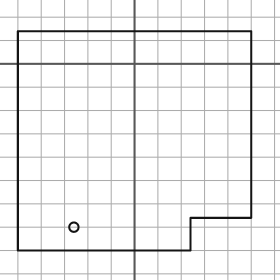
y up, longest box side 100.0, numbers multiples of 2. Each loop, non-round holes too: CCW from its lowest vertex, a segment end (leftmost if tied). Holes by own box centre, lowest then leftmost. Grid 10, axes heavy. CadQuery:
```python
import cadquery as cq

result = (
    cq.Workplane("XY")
    .moveTo(-50.0, -80.0)
    .lineTo(24.0, -80.0)
    .lineTo(24.0, -66.0)
    .lineTo(50.0, -66.0)
    .lineTo(50.0, 14.0)
    .lineTo(-50.0, 14.0)
    .close()
    .moveTo(-26.0, -70.0)
    .circle(2.0)
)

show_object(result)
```